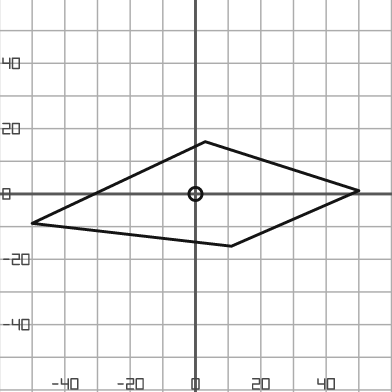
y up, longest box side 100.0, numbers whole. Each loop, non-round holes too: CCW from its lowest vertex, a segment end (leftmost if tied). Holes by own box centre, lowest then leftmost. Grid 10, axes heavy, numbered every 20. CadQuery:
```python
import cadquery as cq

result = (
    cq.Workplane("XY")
    .moveTo(11.0, -16.0)
    .lineTo(50.0, 1.0)
    .lineTo(3.0, 16.0)
    .lineTo(-50.0, -9.0)
    .close()
    .moveTo(0.0, 0.0)
    .circle(2.0)
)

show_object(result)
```